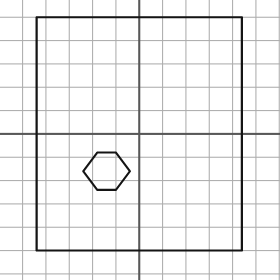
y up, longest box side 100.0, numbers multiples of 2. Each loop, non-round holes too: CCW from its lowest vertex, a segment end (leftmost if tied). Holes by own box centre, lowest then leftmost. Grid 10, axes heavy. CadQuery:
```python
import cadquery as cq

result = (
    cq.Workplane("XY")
    .moveTo(-44.0, -50.0)
    .lineTo(44.0, -50.0)
    .lineTo(44.0, 50.0)
    .lineTo(-44.0, 50.0)
    .close()
    .moveTo(-18.0, -24.0)
    .lineTo(-10.0, -24.0)
    .lineTo(-4.0, -16.0)
    .lineTo(-10.0, -8.0)
    .lineTo(-18.0, -8.0)
    .lineTo(-24.0, -16.0)
    .close()
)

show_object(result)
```